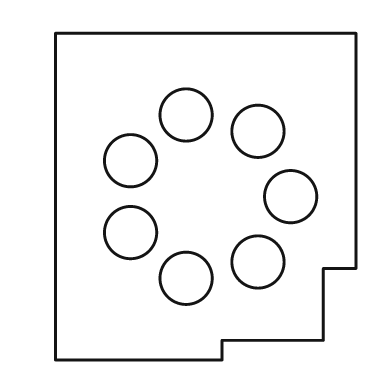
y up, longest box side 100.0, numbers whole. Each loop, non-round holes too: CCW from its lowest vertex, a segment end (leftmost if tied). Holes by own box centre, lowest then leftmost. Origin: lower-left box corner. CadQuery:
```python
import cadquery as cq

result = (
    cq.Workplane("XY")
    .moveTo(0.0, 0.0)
    .lineTo(51.0, 0.0)
    .lineTo(51.0, 6.0)
    .lineTo(82.0, 6.0)
    .lineTo(82.0, 28.0)
    .lineTo(92.0, 28.0)
    .lineTo(92.0, 100.0)
    .lineTo(0.0, 100.0)
    .close()
    .moveTo(40.0, 25.0)
    .circle(8.0)
    .moveTo(62.0, 30.0)
    .circle(8.0)
    .moveTo(23.0, 39.0)
    .circle(8.0)
    .moveTo(72.0, 50.0)
    .circle(8.0)
    .moveTo(23.0, 61.0)
    .circle(8.0)
    .moveTo(62.0, 70.0)
    .circle(8.0)
    .moveTo(40.0, 75.0)
    .circle(8.0)
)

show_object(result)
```